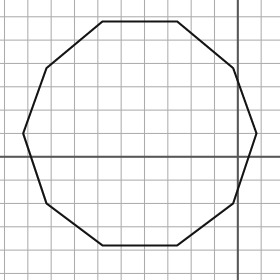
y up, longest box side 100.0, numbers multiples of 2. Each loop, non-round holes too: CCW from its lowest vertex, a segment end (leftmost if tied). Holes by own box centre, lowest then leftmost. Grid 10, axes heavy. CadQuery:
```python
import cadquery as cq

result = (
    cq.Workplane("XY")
    .moveTo(-58.0, -38.0)
    .lineTo(-26.0, -38.0)
    .lineTo(-2.0, -20.0)
    .lineTo(8.0, 10.0)
    .lineTo(-2.0, 38.0)
    .lineTo(-26.0, 58.0)
    .lineTo(-58.0, 58.0)
    .lineTo(-82.0, 38.0)
    .lineTo(-92.0, 10.0)
    .lineTo(-82.0, -20.0)
    .close()
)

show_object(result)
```